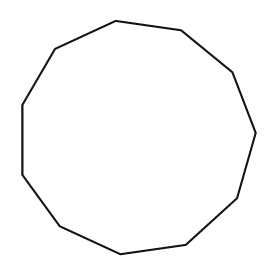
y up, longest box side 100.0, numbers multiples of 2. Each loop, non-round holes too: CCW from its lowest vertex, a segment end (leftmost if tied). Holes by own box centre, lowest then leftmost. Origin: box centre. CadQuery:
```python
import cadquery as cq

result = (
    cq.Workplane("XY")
    .moveTo(-8.0, -50.0)
    .lineTo(20.0, -46.0)
    .lineTo(42.0, -26.0)
    .lineTo(50.0, 2.0)
    .lineTo(40.0, 28.0)
    .lineTo(18.0, 46.0)
    .lineTo(-10.0, 50.0)
    .lineTo(-36.0, 38.0)
    .lineTo(-50.0, 14.0)
    .lineTo(-50.0, -16.0)
    .lineTo(-34.0, -38.0)
    .close()
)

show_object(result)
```